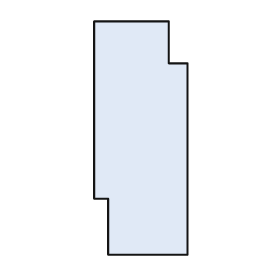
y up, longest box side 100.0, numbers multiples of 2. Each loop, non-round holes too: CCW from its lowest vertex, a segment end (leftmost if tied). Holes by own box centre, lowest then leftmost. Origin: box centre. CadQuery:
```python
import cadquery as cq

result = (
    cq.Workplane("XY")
    .moveTo(-14.0, -50.0)
    .lineTo(20.0, -50.0)
    .lineTo(20.0, 32.0)
    .lineTo(12.0, 32.0)
    .lineTo(12.0, 50.0)
    .lineTo(-20.0, 50.0)
    .lineTo(-20.0, -26.0)
    .lineTo(-14.0, -26.0)
    .close()
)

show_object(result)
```